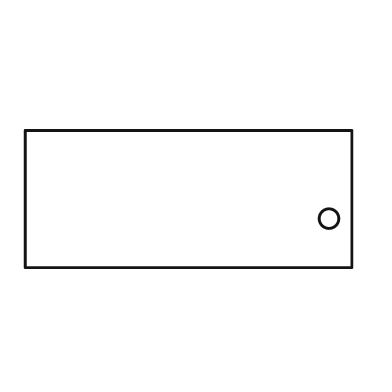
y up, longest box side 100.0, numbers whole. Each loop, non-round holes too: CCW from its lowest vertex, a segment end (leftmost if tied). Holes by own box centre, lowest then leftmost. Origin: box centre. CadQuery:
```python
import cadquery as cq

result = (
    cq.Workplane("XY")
    .moveTo(-50.0, -21.0)
    .lineTo(50.0, -21.0)
    .lineTo(50.0, 21.0)
    .lineTo(-50.0, 21.0)
    .close()
    .moveTo(43.0, -6.0)
    .circle(3.0)
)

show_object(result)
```